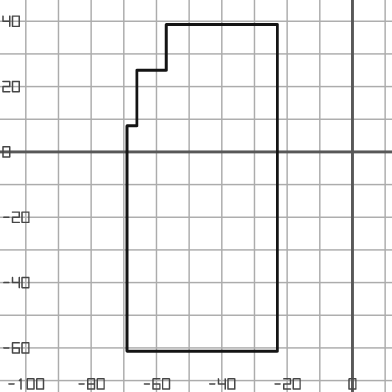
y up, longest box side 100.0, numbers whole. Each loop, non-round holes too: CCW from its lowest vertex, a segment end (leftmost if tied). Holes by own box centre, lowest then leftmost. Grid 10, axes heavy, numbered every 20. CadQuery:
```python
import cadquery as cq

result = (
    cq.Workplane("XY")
    .moveTo(-69.0, -61.0)
    .lineTo(-23.0, -61.0)
    .lineTo(-23.0, 39.0)
    .lineTo(-57.0, 39.0)
    .lineTo(-57.0, 25.0)
    .lineTo(-66.0, 25.0)
    .lineTo(-66.0, 8.0)
    .lineTo(-69.0, 8.0)
    .close()
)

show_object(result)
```